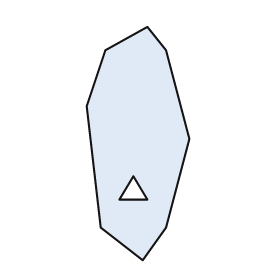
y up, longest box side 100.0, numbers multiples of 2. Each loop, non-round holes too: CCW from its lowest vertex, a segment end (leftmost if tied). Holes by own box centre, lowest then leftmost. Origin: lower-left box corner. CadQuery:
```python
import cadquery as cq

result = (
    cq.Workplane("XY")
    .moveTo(24.0, 0.0)
    .lineTo(34.0, 14.0)
    .lineTo(44.0, 52.0)
    .lineTo(34.0, 90.0)
    .lineTo(26.0, 100.0)
    .lineTo(8.0, 90.0)
    .lineTo(0.0, 66.0)
    .lineTo(6.0, 14.0)
    .close()
    .moveTo(14.0, 26.0)
    .lineTo(26.0, 26.0)
    .lineTo(20.0, 36.0)
    .close()
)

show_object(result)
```